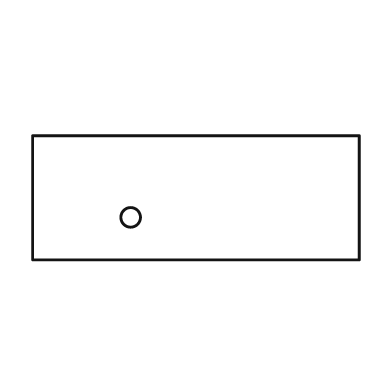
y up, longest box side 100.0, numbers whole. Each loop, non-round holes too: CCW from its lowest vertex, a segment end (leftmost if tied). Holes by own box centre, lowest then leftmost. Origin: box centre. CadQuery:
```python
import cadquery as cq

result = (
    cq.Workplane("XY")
    .moveTo(-50.0, -19.0)
    .lineTo(50.0, -19.0)
    .lineTo(50.0, 19.0)
    .lineTo(-50.0, 19.0)
    .close()
    .moveTo(-20.0, -6.0)
    .circle(3.0)
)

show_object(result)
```